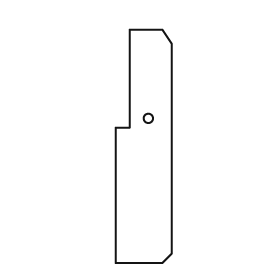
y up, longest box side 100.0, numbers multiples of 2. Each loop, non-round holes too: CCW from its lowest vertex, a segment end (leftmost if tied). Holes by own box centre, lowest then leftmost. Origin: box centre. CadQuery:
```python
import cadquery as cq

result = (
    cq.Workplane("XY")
    .moveTo(-12.0, -50.0)
    .lineTo(8.0, -50.0)
    .lineTo(12.0, -46.0)
    .lineTo(12.0, 44.0)
    .lineTo(8.0, 50.0)
    .lineTo(-6.0, 50.0)
    .lineTo(-6.0, 8.0)
    .lineTo(-12.0, 8.0)
    .close()
    .moveTo(2.0, 12.0)
    .circle(2.0)
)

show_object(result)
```